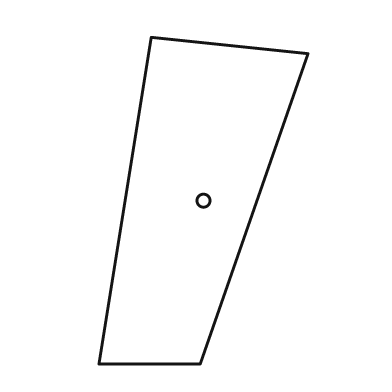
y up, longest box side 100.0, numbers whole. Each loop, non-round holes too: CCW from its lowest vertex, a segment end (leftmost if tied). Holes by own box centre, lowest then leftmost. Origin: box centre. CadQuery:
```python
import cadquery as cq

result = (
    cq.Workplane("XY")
    .moveTo(-32.0, -50.0)
    .lineTo(-1.0, -50.0)
    .lineTo(32.0, 45.0)
    .lineTo(-16.0, 50.0)
    .close()
    .moveTo(0.0, 0.0)
    .circle(2.0)
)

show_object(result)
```